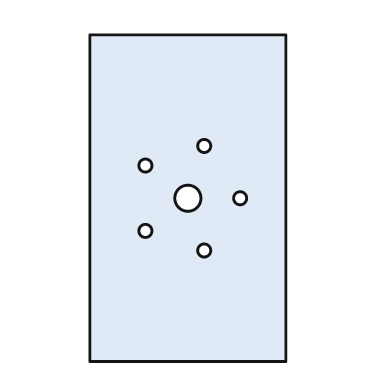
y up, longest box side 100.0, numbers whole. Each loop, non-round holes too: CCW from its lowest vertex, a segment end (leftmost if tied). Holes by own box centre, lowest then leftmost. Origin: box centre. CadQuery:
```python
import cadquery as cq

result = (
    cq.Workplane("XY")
    .moveTo(-30.0, -50.0)
    .lineTo(30.0, -50.0)
    .lineTo(30.0, 50.0)
    .lineTo(-30.0, 50.0)
    .close()
    .moveTo(5.0, -16.0)
    .circle(2.0)
    .moveTo(-13.0, -10.0)
    .circle(2.0)
    .moveTo(0.0, 0.0)
    .circle(4.0)
    .moveTo(16.0, 0.0)
    .circle(2.0)
    .moveTo(-13.0, 10.0)
    .circle(2.0)
    .moveTo(5.0, 16.0)
    .circle(2.0)
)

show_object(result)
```